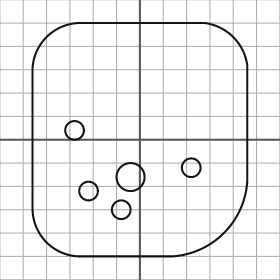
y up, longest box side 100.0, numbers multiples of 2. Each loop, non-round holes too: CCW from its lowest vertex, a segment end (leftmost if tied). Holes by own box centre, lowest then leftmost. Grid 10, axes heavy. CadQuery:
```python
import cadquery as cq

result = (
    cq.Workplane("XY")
    .moveTo(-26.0, -50.0)
    .lineTo(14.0, -50.0)
    .threePointArc((36.0, -40.0), (46.0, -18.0))
    .lineTo(46.0, 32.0)
    .threePointArc((40.0, 44.0), (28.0, 50.0))
    .lineTo(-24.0, 50.0)
    .threePointArc((-40.0, 44.0), (-46.0, 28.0))
    .lineTo(-46.0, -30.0)
    .threePointArc((-40.0, -44.0), (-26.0, -50.0))
    .close()
    .moveTo(-8.0, -30.0)
    .circle(4.0)
    .moveTo(-22.0, -22.0)
    .circle(4.0)
    .moveTo(-4.0, -16.0)
    .circle(6.0)
    .moveTo(22.0, -12.0)
    .circle(4.0)
    .moveTo(-28.0, 4.0)
    .circle(4.0)
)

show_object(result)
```